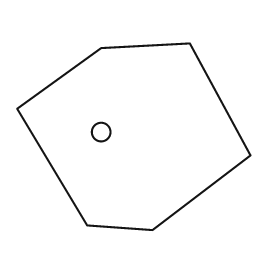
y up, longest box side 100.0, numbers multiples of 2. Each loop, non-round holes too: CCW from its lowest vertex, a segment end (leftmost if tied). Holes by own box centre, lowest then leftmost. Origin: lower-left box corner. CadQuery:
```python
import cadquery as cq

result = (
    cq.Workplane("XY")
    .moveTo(58.0, 0.0)
    .lineTo(100.0, 32.0)
    .lineTo(74.0, 80.0)
    .lineTo(36.0, 78.0)
    .lineTo(0.0, 52.0)
    .lineTo(30.0, 2.0)
    .close()
    .moveTo(36.0, 42.0)
    .circle(4.0)
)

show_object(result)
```